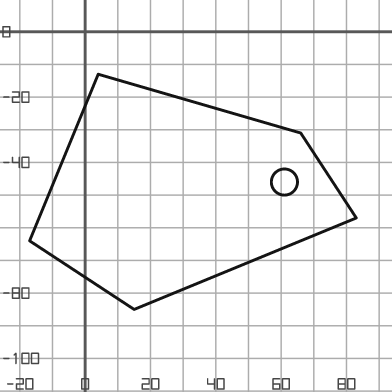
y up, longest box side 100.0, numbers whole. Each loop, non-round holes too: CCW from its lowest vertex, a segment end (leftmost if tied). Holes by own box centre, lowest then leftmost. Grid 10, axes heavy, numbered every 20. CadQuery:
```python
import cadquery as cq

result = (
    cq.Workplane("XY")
    .moveTo(15.0, -85.0)
    .lineTo(83.0, -57.0)
    .lineTo(66.0, -31.0)
    .lineTo(4.0, -13.0)
    .lineTo(-17.0, -64.0)
    .close()
    .moveTo(61.0, -46.0)
    .circle(4.0)
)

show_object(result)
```